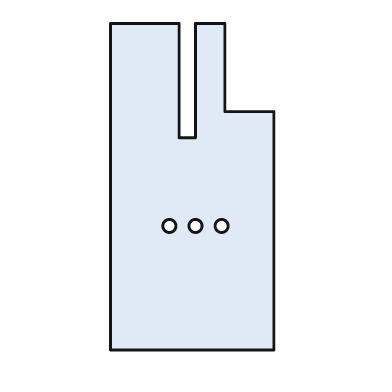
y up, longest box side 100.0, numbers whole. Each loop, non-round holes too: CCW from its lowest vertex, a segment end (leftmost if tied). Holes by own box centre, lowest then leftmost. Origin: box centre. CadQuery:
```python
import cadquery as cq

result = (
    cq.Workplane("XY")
    .moveTo(-25.0, -50.0)
    .lineTo(25.0, -50.0)
    .lineTo(25.0, 23.0)
    .lineTo(10.0, 23.0)
    .lineTo(10.0, 50.0)
    .lineTo(1.0, 50.0)
    .lineTo(1.0, 15.0)
    .lineTo(-4.0, 15.0)
    .lineTo(-4.0, 50.0)
    .lineTo(-25.0, 50.0)
    .close()
    .moveTo(-7.0, -12.0)
    .circle(2.0)
    .moveTo(1.0, -12.0)
    .circle(2.0)
    .moveTo(9.0, -12.0)
    .circle(2.0)
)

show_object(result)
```